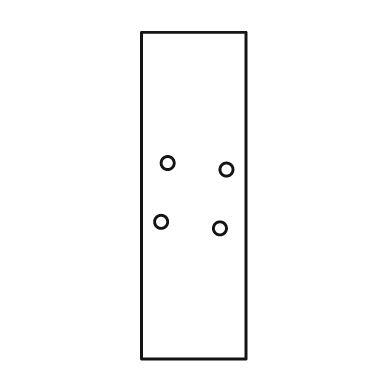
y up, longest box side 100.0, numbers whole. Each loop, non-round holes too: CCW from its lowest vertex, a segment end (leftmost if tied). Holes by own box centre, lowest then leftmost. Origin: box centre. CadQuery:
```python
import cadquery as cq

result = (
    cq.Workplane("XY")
    .moveTo(-16.0, -50.0)
    .lineTo(16.0, -50.0)
    .lineTo(16.0, 50.0)
    .lineTo(-16.0, 50.0)
    .close()
    .moveTo(8.0, -10.0)
    .circle(2.0)
    .moveTo(-10.0, -8.0)
    .circle(2.0)
    .moveTo(10.0, 8.0)
    .circle(2.0)
    .moveTo(-8.0, 10.0)
    .circle(2.0)
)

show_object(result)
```